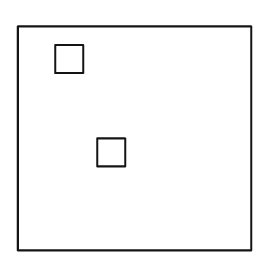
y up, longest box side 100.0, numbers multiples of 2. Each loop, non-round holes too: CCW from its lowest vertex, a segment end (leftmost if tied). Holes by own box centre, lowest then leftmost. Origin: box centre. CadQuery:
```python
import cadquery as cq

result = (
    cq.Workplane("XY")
    .moveTo(-50.0, -48.0)
    .lineTo(50.0, -48.0)
    .lineTo(50.0, 48.0)
    .lineTo(-50.0, 48.0)
    .close()
    .moveTo(-16.0, -12.0)
    .lineTo(-4.0, -12.0)
    .lineTo(-4.0, 0.0)
    .lineTo(-16.0, 0.0)
    .close()
    .moveTo(-34.0, 28.0)
    .lineTo(-22.0, 28.0)
    .lineTo(-22.0, 40.0)
    .lineTo(-34.0, 40.0)
    .close()
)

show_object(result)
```